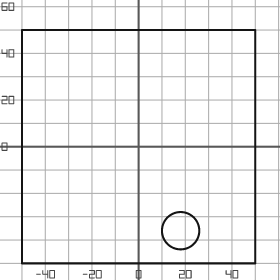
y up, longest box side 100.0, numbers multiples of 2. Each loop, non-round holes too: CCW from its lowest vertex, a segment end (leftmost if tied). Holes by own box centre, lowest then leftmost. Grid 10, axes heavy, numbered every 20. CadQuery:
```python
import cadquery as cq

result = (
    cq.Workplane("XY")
    .moveTo(-50.0, -50.0)
    .lineTo(50.0, -50.0)
    .lineTo(50.0, 50.0)
    .lineTo(-50.0, 50.0)
    .close()
    .moveTo(18.0, -36.0)
    .circle(8.0)
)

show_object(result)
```